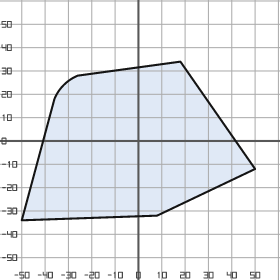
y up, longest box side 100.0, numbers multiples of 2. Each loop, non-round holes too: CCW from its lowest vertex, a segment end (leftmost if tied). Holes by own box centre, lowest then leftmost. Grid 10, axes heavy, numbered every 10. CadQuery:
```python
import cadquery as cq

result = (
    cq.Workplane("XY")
    .moveTo(-50.0, -34.0)
    .lineTo(8.0, -32.0)
    .lineTo(50.0, -12.0)
    .lineTo(18.0, 34.0)
    .lineTo(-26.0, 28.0)
    .threePointArc((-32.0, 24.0), (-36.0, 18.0))
    .close()
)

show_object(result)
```